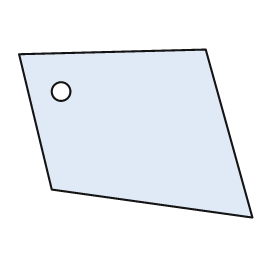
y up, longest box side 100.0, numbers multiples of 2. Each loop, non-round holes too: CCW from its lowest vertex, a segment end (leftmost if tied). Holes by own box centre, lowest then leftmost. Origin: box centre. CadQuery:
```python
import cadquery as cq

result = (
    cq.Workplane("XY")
    .moveTo(50.0, -36.0)
    .lineTo(30.0, 36.0)
    .lineTo(-50.0, 34.0)
    .lineTo(-36.0, -24.0)
    .close()
    .moveTo(-32.0, 18.0)
    .circle(4.0)
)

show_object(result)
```